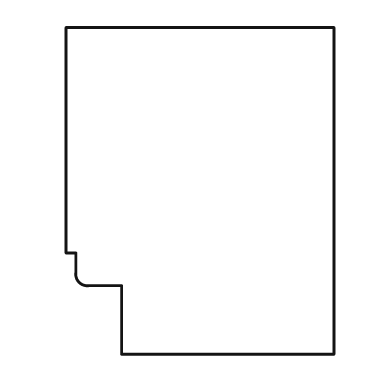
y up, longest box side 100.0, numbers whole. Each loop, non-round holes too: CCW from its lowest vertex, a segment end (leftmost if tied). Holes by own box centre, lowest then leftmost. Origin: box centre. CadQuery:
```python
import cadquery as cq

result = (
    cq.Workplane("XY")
    .moveTo(-24.0, -50.0)
    .lineTo(41.0, -50.0)
    .lineTo(41.0, 50.0)
    .lineTo(-41.0, 50.0)
    .lineTo(-41.0, -19.0)
    .lineTo(-38.0, -19.0)
    .lineTo(-38.0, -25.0)
    .threePointArc((-37.0, -28.0), (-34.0, -29.0))
    .lineTo(-24.0, -29.0)
    .close()
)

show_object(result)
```